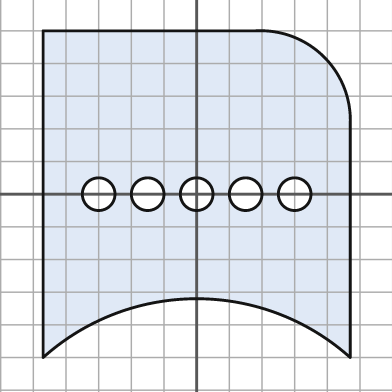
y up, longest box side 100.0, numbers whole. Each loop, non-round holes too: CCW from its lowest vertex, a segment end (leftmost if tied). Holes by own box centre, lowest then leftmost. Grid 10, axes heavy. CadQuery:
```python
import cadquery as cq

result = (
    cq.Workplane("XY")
    .moveTo(-47.0, -50.0)
    .threePointArc((0.0, -32.0), (47.0, -50.0))
    .lineTo(47.0, 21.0)
    .threePointArc((39.0, 42.0), (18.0, 50.0))
    .lineTo(-47.0, 50.0)
    .close()
    .moveTo(-30.0, 0.0)
    .circle(5.0)
    .moveTo(-15.0, 0.0)
    .circle(5.0)
    .moveTo(0.0, 0.0)
    .circle(5.0)
    .moveTo(15.0, 0.0)
    .circle(5.0)
    .moveTo(30.0, 0.0)
    .circle(5.0)
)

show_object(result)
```